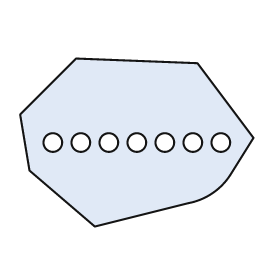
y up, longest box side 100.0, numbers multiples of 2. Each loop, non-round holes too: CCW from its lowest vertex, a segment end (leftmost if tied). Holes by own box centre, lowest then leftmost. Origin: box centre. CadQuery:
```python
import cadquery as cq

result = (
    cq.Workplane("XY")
    .moveTo(-18.0, -36.0)
    .lineTo(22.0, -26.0)
    .threePointArc((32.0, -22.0), (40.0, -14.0))
    .lineTo(50.0, 2.0)
    .lineTo(26.0, 34.0)
    .lineTo(-26.0, 36.0)
    .lineTo(-50.0, 12.0)
    .lineTo(-46.0, -12.0)
    .close()
    .moveTo(-36.0, 0.0)
    .circle(4.0)
    .moveTo(-24.0, 0.0)
    .circle(4.0)
    .moveTo(-12.0, 0.0)
    .circle(4.0)
    .moveTo(0.0, 0.0)
    .circle(4.0)
    .moveTo(12.0, 0.0)
    .circle(4.0)
    .moveTo(24.0, 0.0)
    .circle(4.0)
    .moveTo(36.0, 0.0)
    .circle(4.0)
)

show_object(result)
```